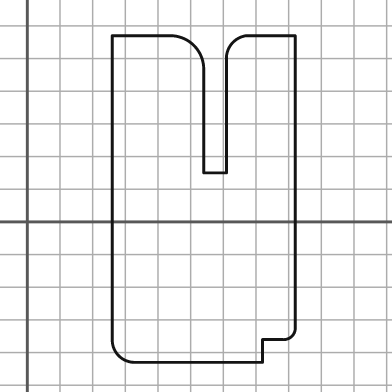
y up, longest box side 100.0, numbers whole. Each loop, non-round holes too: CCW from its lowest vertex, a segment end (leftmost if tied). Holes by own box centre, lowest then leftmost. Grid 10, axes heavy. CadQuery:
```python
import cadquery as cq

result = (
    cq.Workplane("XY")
    .moveTo(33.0, -43.0)
    .lineTo(72.0, -43.0)
    .lineTo(72.0, -36.0)
    .lineTo(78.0, -36.0)
    .threePointArc((81.0, -35.0), (82.0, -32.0))
    .lineTo(82.0, 57.0)
    .lineTo(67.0, 57.0)
    .threePointArc((63.0, 55.0), (61.0, 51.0))
    .lineTo(61.0, 15.0)
    .lineTo(54.0, 15.0)
    .lineTo(54.0, 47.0)
    .threePointArc((51.0, 54.0), (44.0, 57.0))
    .lineTo(26.0, 57.0)
    .lineTo(26.0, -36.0)
    .threePointArc((28.0, -41.0), (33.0, -43.0))
    .close()
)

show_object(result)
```